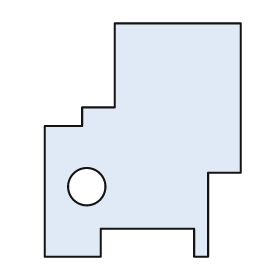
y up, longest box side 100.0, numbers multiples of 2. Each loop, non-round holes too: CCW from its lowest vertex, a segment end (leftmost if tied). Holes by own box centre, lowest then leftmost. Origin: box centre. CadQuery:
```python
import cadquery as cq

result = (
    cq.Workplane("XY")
    .moveTo(-42.0, -50.0)
    .lineTo(-18.0, -50.0)
    .lineTo(-18.0, -38.0)
    .lineTo(22.0, -38.0)
    .lineTo(22.0, -50.0)
    .lineTo(28.0, -50.0)
    .lineTo(28.0, -14.0)
    .lineTo(42.0, -14.0)
    .lineTo(42.0, 50.0)
    .lineTo(-12.0, 50.0)
    .lineTo(-12.0, 14.0)
    .lineTo(-26.0, 14.0)
    .lineTo(-26.0, 6.0)
    .lineTo(-42.0, 6.0)
    .close()
    .moveTo(-24.0, -20.0)
    .circle(8.0)
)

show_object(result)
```